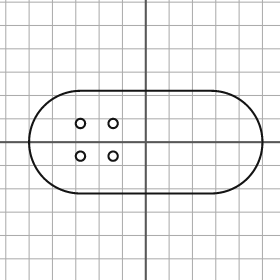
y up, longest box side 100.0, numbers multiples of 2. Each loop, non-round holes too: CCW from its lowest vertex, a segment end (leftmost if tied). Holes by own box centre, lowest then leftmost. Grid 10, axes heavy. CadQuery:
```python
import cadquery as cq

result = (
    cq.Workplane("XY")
    .moveTo(-28.0, -22.0)
    .lineTo(28.0, -22.0)
    .threePointArc((50.0, 0.0), (28.0, 22.0))
    .lineTo(-28.0, 22.0)
    .threePointArc((-50.0, 0.0), (-28.0, -22.0))
    .close()
    .moveTo(-28.0, -6.0)
    .circle(2.0)
    .moveTo(-14.0, -6.0)
    .circle(2.0)
    .moveTo(-28.0, 8.0)
    .circle(2.0)
    .moveTo(-14.0, 8.0)
    .circle(2.0)
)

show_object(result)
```